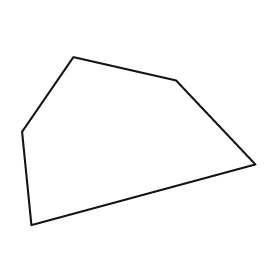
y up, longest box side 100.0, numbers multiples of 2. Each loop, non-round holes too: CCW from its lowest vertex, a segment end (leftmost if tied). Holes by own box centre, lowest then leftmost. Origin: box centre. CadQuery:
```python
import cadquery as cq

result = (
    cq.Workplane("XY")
    .moveTo(-46.0, -36.0)
    .lineTo(50.0, -10.0)
    .lineTo(16.0, 26.0)
    .lineTo(-28.0, 36.0)
    .lineTo(-50.0, 4.0)
    .close()
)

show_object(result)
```